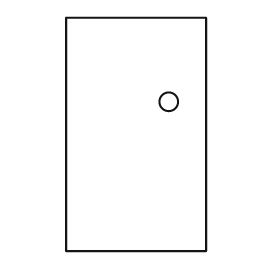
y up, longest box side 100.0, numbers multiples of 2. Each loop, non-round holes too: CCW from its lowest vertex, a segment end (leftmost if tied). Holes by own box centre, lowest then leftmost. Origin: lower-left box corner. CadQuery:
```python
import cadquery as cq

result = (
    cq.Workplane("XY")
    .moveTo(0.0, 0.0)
    .lineTo(60.0, 0.0)
    .lineTo(60.0, 100.0)
    .lineTo(0.0, 100.0)
    .close()
    .moveTo(44.0, 64.0)
    .circle(4.0)
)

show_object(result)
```